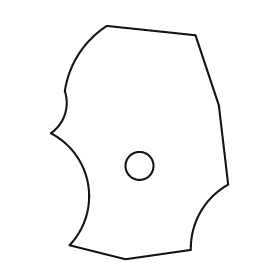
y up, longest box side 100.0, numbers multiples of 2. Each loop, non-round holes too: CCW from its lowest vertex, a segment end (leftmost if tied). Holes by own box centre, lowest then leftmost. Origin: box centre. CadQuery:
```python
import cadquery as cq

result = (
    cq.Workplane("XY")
    .moveTo(-6.0, -50.0)
    .lineTo(22.0, -46.0)
    .threePointArc((26.0, -30.0), (38.0, -18.0))
    .lineTo(34.0, 16.0)
    .lineTo(24.0, 46.0)
    .lineTo(-14.0, 50.0)
    .threePointArc((-26.0, 38.0), (-32.0, 22.0))
    .threePointArc((-32.0, 12.0), (-38.0, 4.0))
    .threePointArc((-22.0, -18.0), (-30.0, -44.0))
    .close()
    .moveTo(0.0, -10.0)
    .circle(6.0)
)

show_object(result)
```